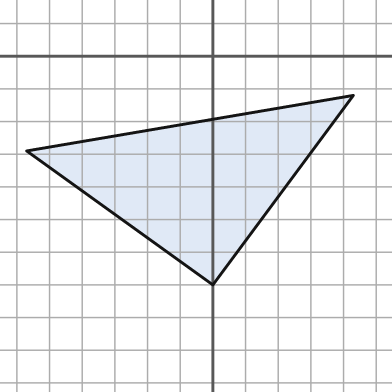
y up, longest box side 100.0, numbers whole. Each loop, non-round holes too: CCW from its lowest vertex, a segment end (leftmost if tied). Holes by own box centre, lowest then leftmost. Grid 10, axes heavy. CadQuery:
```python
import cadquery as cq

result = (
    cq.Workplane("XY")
    .moveTo(0.0, -70.0)
    .lineTo(43.0, -12.0)
    .lineTo(-57.0, -29.0)
    .close()
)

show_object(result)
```